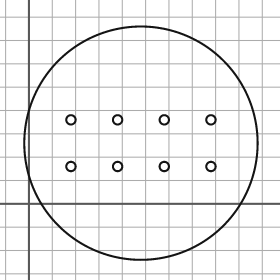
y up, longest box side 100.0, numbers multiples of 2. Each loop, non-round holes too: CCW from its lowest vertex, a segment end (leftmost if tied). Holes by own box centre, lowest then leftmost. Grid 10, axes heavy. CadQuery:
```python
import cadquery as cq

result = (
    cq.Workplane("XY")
    .moveTo(48.0, 26.0)
    .circle(50.0)
    .moveTo(18.0, 16.0)
    .circle(2.0)
    .moveTo(38.0, 16.0)
    .circle(2.0)
    .moveTo(58.0, 16.0)
    .circle(2.0)
    .moveTo(78.0, 16.0)
    .circle(2.0)
    .moveTo(18.0, 36.0)
    .circle(2.0)
    .moveTo(38.0, 36.0)
    .circle(2.0)
    .moveTo(58.0, 36.0)
    .circle(2.0)
    .moveTo(78.0, 36.0)
    .circle(2.0)
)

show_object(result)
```